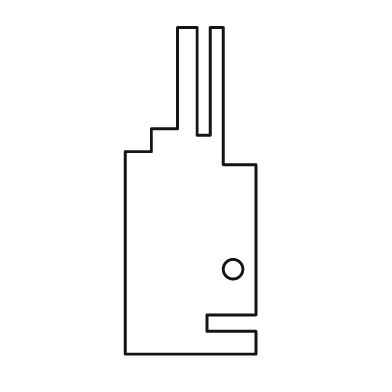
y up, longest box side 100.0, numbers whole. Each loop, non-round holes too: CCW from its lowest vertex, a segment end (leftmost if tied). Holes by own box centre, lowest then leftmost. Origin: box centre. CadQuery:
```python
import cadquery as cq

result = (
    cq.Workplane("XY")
    .moveTo(-20.0, -50.0)
    .lineTo(20.0, -50.0)
    .lineTo(20.0, -43.0)
    .lineTo(5.0, -43.0)
    .lineTo(5.0, -38.0)
    .lineTo(20.0, -38.0)
    .lineTo(20.0, 8.0)
    .lineTo(10.0, 8.0)
    .lineTo(10.0, 50.0)
    .lineTo(6.0, 50.0)
    .lineTo(6.0, 17.0)
    .lineTo(2.0, 17.0)
    .lineTo(2.0, 50.0)
    .lineTo(-4.0, 50.0)
    .lineTo(-4.0, 19.0)
    .lineTo(-12.0, 19.0)
    .lineTo(-12.0, 12.0)
    .lineTo(-20.0, 12.0)
    .close()
    .moveTo(13.0, -24.0)
    .circle(3.0)
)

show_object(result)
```